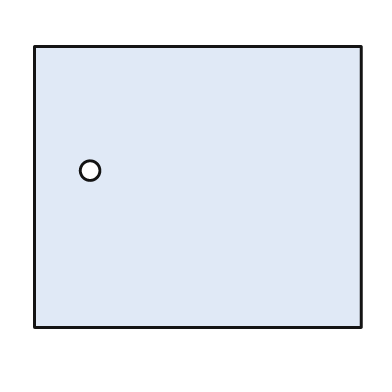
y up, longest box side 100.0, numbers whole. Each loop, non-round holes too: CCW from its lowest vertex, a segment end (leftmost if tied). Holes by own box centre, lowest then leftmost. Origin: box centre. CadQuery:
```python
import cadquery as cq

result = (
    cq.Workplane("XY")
    .moveTo(-50.0, -43.0)
    .lineTo(50.0, -43.0)
    .lineTo(50.0, 43.0)
    .lineTo(-50.0, 43.0)
    .close()
    .moveTo(-33.0, 5.0)
    .circle(3.0)
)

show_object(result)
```